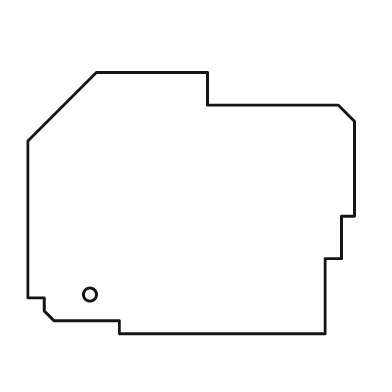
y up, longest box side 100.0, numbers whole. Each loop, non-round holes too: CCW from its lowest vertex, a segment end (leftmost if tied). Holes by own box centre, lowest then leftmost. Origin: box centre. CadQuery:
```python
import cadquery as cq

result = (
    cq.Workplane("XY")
    .moveTo(-22.0, -40.0)
    .lineTo(41.0, -40.0)
    .lineTo(41.0, -17.0)
    .lineTo(46.0, -17.0)
    .lineTo(46.0, -4.0)
    .lineTo(50.0, -4.0)
    .lineTo(50.0, 25.0)
    .lineTo(45.0, 30.0)
    .lineTo(5.0, 30.0)
    .lineTo(5.0, 40.0)
    .lineTo(-29.0, 40.0)
    .lineTo(-50.0, 19.0)
    .lineTo(-50.0, -29.0)
    .lineTo(-45.0, -29.0)
    .lineTo(-45.0, -33.0)
    .lineTo(-42.0, -36.0)
    .lineTo(-22.0, -36.0)
    .close()
    .moveTo(-31.0, -28.0)
    .circle(2.0)
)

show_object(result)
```